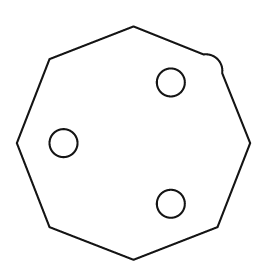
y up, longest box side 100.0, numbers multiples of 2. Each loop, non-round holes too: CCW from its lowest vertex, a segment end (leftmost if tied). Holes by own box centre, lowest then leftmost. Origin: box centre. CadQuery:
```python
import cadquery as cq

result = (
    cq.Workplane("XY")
    .moveTo(0.0, -50.0)
    .lineTo(36.0, -36.0)
    .lineTo(50.0, 0.0)
    .lineTo(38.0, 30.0)
    .threePointArc((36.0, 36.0), (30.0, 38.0))
    .lineTo(0.0, 50.0)
    .lineTo(-36.0, 36.0)
    .lineTo(-50.0, 0.0)
    .lineTo(-36.0, -36.0)
    .close()
    .moveTo(16.0, -26.0)
    .circle(6.0)
    .moveTo(-30.0, 0.0)
    .circle(6.0)
    .moveTo(16.0, 26.0)
    .circle(6.0)
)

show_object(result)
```